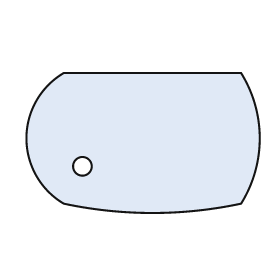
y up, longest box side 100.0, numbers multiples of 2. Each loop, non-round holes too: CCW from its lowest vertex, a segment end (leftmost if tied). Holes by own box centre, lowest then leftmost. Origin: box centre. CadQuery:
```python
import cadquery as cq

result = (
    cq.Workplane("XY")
    .moveTo(-34.0, -26.0)
    .threePointArc((4.0, -30.0), (42.0, -26.0))
    .threePointArc((50.0, 2.0), (42.0, 30.0))
    .lineTo(-34.0, 30.0)
    .threePointArc((-50.0, 2.0), (-34.0, -26.0))
    .close()
    .moveTo(-26.0, -10.0)
    .circle(4.0)
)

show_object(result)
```